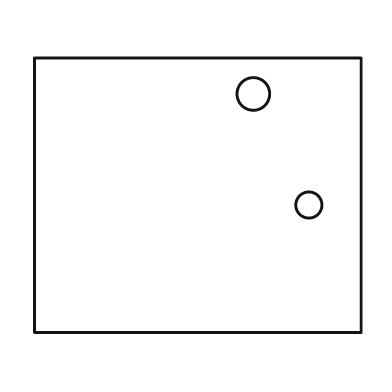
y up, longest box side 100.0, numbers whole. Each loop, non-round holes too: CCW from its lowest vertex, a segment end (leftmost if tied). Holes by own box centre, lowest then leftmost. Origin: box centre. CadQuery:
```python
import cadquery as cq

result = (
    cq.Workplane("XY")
    .moveTo(-50.0, -42.0)
    .lineTo(50.0, -42.0)
    .lineTo(50.0, 42.0)
    .lineTo(-50.0, 42.0)
    .close()
    .moveTo(34.0, -3.0)
    .circle(4.0)
    .moveTo(17.0, 31.0)
    .circle(5.0)
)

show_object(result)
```